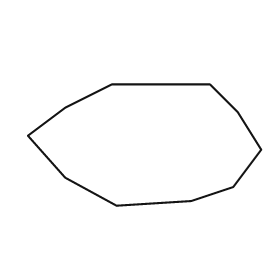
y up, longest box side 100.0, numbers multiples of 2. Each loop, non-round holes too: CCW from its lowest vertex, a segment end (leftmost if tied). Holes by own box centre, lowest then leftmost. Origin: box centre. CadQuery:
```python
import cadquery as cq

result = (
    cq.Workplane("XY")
    .moveTo(-12.0, -26.0)
    .lineTo(20.0, -24.0)
    .lineTo(38.0, -18.0)
    .lineTo(50.0, -2.0)
    .lineTo(40.0, 14.0)
    .lineTo(28.0, 26.0)
    .lineTo(-14.0, 26.0)
    .lineTo(-34.0, 16.0)
    .lineTo(-50.0, 4.0)
    .lineTo(-34.0, -14.0)
    .close()
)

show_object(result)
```